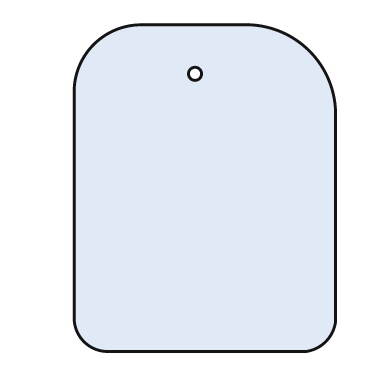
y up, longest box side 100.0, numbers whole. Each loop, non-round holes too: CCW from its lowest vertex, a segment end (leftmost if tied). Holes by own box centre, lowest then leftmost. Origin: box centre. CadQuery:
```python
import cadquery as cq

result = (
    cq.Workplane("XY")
    .moveTo(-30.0, -50.0)
    .lineTo(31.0, -50.0)
    .threePointArc((37.0, -47.0), (40.0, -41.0))
    .lineTo(40.0, 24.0)
    .threePointArc((32.0, 42.0), (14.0, 50.0))
    .lineTo(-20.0, 50.0)
    .threePointArc((-34.0, 44.0), (-40.0, 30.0))
    .lineTo(-40.0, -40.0)
    .threePointArc((-37.0, -47.0), (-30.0, -50.0))
    .close()
    .moveTo(-3.0, 35.0)
    .circle(2.0)
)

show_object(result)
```